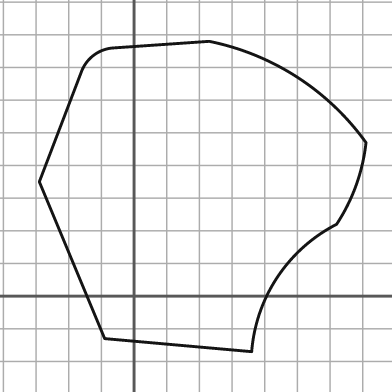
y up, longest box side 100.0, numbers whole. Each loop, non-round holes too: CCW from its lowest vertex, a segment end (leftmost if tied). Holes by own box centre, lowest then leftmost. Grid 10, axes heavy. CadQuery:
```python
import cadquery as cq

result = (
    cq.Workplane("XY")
    .moveTo(36.0, -17.0)
    .threePointArc((44.0, 6.0), (62.0, 22.0))
    .threePointArc((68.0, 34.0), (71.0, 47.0))
    .threePointArc((50.0, 67.0), (23.0, 78.0))
    .lineTo(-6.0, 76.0)
    .threePointArc((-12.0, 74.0), (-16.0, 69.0))
    .lineTo(-29.0, 35.0)
    .lineTo(-9.0, -13.0)
    .close()
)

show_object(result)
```